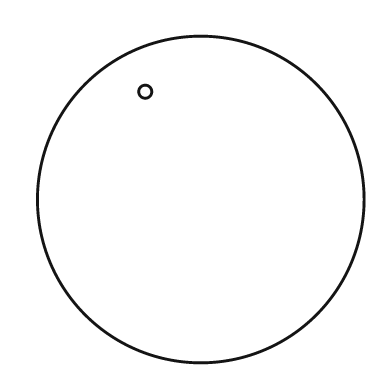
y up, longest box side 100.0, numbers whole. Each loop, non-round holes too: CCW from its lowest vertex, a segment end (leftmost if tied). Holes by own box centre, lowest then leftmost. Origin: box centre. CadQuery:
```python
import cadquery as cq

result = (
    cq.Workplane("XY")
    .moveTo(0.0, 0.0)
    .circle(50.0)
    .moveTo(-17.0, 33.0)
    .circle(2.0)
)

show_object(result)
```